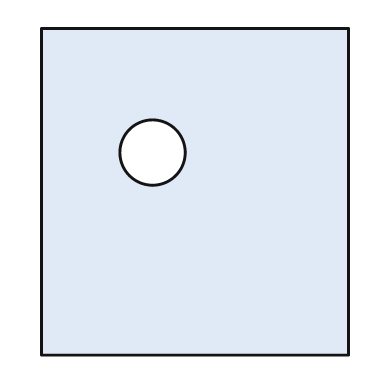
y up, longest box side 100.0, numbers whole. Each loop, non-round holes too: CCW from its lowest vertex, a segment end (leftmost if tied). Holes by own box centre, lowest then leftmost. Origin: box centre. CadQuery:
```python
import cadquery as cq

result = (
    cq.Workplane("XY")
    .moveTo(-47.0, -50.0)
    .lineTo(47.0, -50.0)
    .lineTo(47.0, 50.0)
    .lineTo(-47.0, 50.0)
    .close()
    .moveTo(-13.0, 12.0)
    .circle(10.0)
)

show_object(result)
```